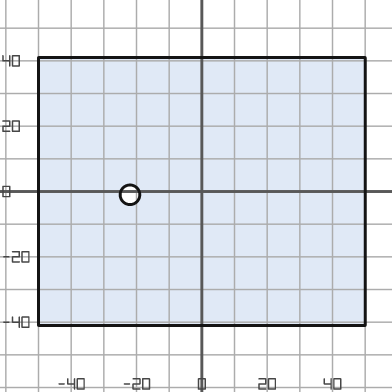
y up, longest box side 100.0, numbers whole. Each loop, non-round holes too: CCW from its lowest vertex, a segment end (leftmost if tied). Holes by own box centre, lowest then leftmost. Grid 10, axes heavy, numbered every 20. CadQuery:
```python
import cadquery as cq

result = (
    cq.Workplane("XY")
    .moveTo(-50.0, -41.0)
    .lineTo(50.0, -41.0)
    .lineTo(50.0, 41.0)
    .lineTo(-50.0, 41.0)
    .close()
    .moveTo(-22.0, -1.0)
    .circle(3.0)
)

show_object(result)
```